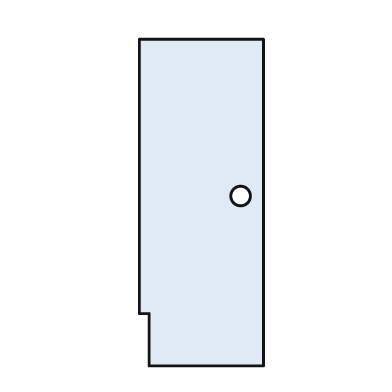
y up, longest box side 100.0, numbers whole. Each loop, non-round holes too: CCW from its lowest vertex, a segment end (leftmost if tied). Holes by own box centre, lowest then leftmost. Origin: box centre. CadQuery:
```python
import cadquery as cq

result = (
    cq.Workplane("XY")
    .moveTo(-16.0, -50.0)
    .lineTo(19.0, -50.0)
    .lineTo(19.0, 50.0)
    .lineTo(-19.0, 50.0)
    .lineTo(-19.0, -34.0)
    .lineTo(-16.0, -34.0)
    .close()
    .moveTo(12.0, 2.0)
    .circle(3.0)
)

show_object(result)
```